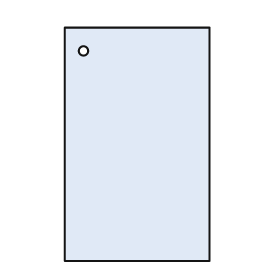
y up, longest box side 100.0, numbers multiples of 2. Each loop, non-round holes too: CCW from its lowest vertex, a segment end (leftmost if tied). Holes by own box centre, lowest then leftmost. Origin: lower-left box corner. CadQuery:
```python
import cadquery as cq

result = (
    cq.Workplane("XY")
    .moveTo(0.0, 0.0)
    .lineTo(62.0, 0.0)
    .lineTo(62.0, 100.0)
    .lineTo(0.0, 100.0)
    .close()
    .moveTo(8.0, 90.0)
    .circle(2.0)
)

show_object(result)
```